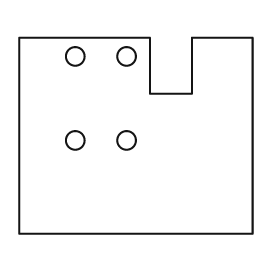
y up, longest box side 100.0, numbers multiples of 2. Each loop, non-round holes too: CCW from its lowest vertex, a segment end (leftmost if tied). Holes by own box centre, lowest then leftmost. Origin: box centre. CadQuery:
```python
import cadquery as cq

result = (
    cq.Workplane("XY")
    .moveTo(-50.0, -42.0)
    .lineTo(50.0, -42.0)
    .lineTo(50.0, 42.0)
    .lineTo(24.0, 42.0)
    .lineTo(24.0, 18.0)
    .lineTo(6.0, 18.0)
    .lineTo(6.0, 42.0)
    .lineTo(-50.0, 42.0)
    .close()
    .moveTo(-26.0, -2.0)
    .circle(4.0)
    .moveTo(-4.0, -2.0)
    .circle(4.0)
    .moveTo(-26.0, 34.0)
    .circle(4.0)
    .moveTo(-4.0, 34.0)
    .circle(4.0)
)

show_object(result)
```